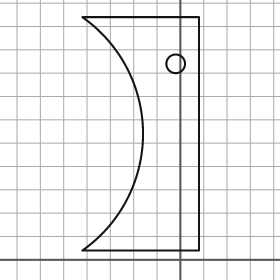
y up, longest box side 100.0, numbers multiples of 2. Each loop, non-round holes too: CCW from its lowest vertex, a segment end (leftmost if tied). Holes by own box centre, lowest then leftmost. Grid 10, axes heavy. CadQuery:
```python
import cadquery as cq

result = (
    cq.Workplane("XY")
    .moveTo(-42.0, 4.0)
    .lineTo(8.0, 4.0)
    .lineTo(8.0, 104.0)
    .lineTo(-42.0, 104.0)
    .threePointArc((-16.0, 54.0), (-42.0, 4.0))
    .close()
    .moveTo(-2.0, 84.0)
    .circle(4.0)
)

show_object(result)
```